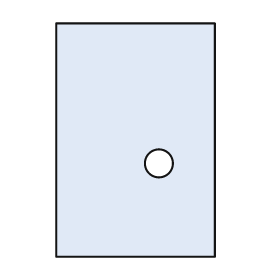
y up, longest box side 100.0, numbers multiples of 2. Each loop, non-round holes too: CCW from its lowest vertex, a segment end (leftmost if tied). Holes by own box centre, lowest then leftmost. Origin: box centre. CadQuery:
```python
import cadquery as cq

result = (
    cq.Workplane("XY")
    .moveTo(-34.0, -50.0)
    .lineTo(34.0, -50.0)
    .lineTo(34.0, 50.0)
    .lineTo(-34.0, 50.0)
    .close()
    .moveTo(10.0, -10.0)
    .circle(6.0)
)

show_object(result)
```